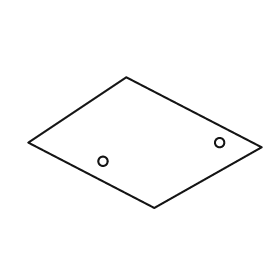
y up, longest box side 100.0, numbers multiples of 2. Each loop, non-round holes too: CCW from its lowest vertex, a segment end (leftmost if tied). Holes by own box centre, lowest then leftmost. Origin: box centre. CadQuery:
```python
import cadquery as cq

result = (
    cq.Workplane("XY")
    .moveTo(4.0, -28.0)
    .lineTo(50.0, -2.0)
    .lineTo(-8.0, 28.0)
    .lineTo(-50.0, 0.0)
    .close()
    .moveTo(-18.0, -8.0)
    .circle(2.0)
    .moveTo(32.0, 0.0)
    .circle(2.0)
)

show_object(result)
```